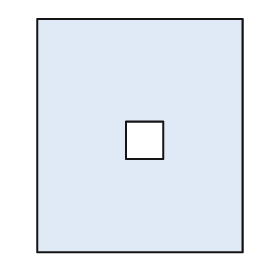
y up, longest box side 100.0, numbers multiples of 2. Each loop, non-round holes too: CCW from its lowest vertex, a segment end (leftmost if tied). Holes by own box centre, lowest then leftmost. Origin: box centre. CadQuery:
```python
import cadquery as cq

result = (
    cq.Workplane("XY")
    .moveTo(-44.0, -50.0)
    .lineTo(44.0, -50.0)
    .lineTo(44.0, 50.0)
    .lineTo(-44.0, 50.0)
    .close()
    .moveTo(-6.0, -10.0)
    .lineTo(10.0, -10.0)
    .lineTo(10.0, 6.0)
    .lineTo(-6.0, 6.0)
    .close()
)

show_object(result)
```